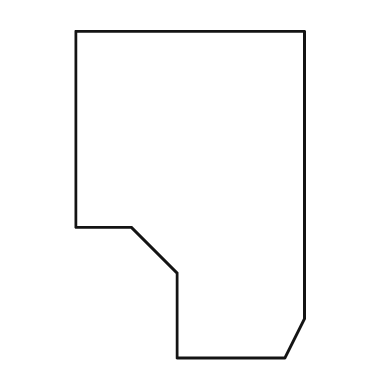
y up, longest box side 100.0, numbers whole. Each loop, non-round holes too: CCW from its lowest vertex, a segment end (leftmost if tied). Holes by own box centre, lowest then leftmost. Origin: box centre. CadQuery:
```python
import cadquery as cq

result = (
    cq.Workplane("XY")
    .moveTo(-4.0, -50.0)
    .lineTo(29.0, -50.0)
    .lineTo(35.0, -38.0)
    .lineTo(35.0, 50.0)
    .lineTo(-35.0, 50.0)
    .lineTo(-35.0, -10.0)
    .lineTo(-18.0, -10.0)
    .lineTo(-4.0, -24.0)
    .close()
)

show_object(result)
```